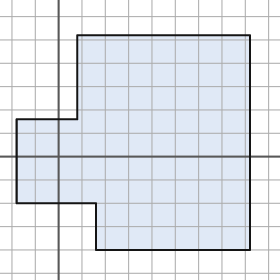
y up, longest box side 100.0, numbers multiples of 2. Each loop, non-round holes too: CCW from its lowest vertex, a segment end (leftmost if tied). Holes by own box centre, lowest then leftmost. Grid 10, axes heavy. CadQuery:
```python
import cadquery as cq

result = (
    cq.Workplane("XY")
    .moveTo(16.0, -40.0)
    .lineTo(82.0, -40.0)
    .lineTo(82.0, 52.0)
    .lineTo(8.0, 52.0)
    .lineTo(8.0, 16.0)
    .lineTo(-18.0, 16.0)
    .lineTo(-18.0, -20.0)
    .lineTo(16.0, -20.0)
    .close()
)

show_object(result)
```